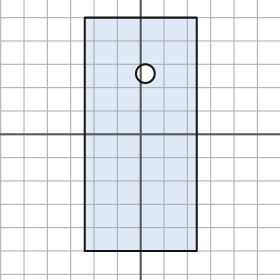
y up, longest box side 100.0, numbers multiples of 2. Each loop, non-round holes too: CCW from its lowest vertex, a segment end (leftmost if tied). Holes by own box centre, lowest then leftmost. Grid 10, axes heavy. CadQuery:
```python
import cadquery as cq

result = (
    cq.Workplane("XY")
    .moveTo(-24.0, -50.0)
    .lineTo(24.0, -50.0)
    .lineTo(24.0, 50.0)
    .lineTo(-24.0, 50.0)
    .close()
    .moveTo(2.0, 26.0)
    .circle(4.0)
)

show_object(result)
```